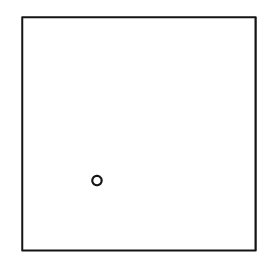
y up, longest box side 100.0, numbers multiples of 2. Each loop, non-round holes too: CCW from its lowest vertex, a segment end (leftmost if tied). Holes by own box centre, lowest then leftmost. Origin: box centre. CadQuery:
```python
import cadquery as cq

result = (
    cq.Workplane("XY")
    .moveTo(-50.0, -50.0)
    .lineTo(50.0, -50.0)
    .lineTo(50.0, 50.0)
    .lineTo(-50.0, 50.0)
    .close()
    .moveTo(-18.0, -20.0)
    .circle(2.0)
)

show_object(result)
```